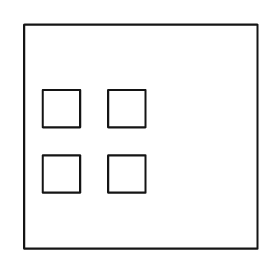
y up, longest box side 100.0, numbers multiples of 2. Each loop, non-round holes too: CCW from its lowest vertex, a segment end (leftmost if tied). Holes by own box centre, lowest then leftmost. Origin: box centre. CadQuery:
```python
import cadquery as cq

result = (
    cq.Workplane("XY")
    .moveTo(-50.0, -48.0)
    .lineTo(50.0, -48.0)
    .lineTo(50.0, 48.0)
    .lineTo(-50.0, 48.0)
    .close()
    .moveTo(-42.0, -24.0)
    .lineTo(-26.0, -24.0)
    .lineTo(-26.0, -8.0)
    .lineTo(-42.0, -8.0)
    .close()
    .moveTo(-14.0, -24.0)
    .lineTo(2.0, -24.0)
    .lineTo(2.0, -8.0)
    .lineTo(-14.0, -8.0)
    .close()
    .moveTo(-42.0, 4.0)
    .lineTo(-26.0, 4.0)
    .lineTo(-26.0, 20.0)
    .lineTo(-42.0, 20.0)
    .close()
    .moveTo(-14.0, 4.0)
    .lineTo(2.0, 4.0)
    .lineTo(2.0, 20.0)
    .lineTo(-14.0, 20.0)
    .close()
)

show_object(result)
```